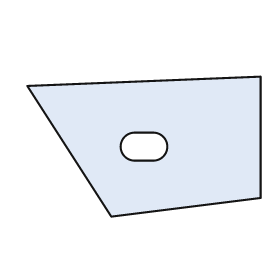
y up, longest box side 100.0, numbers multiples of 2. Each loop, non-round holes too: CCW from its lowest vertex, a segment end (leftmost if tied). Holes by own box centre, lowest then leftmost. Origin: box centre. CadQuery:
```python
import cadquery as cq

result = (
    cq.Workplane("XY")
    .moveTo(-14.0, -30.0)
    .lineTo(50.0, -22.0)
    .lineTo(50.0, 30.0)
    .lineTo(-50.0, 26.0)
    .close()
    .moveTo(-4.0, -6.0)
    .lineTo(4.0, -6.0)
    .threePointArc((10.0, 0.0), (4.0, 6.0))
    .lineTo(-4.0, 6.0)
    .threePointArc((-10.0, 0.0), (-4.0, -6.0))
    .close()
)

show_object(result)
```